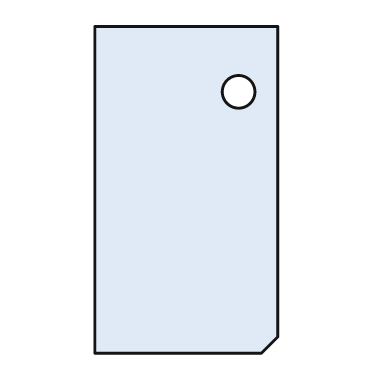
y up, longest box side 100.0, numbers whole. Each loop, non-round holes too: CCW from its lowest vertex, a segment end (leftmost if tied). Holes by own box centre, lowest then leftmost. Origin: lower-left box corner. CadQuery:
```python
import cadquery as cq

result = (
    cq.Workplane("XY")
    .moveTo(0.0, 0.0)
    .lineTo(51.0, 0.0)
    .lineTo(56.0, 5.0)
    .lineTo(56.0, 100.0)
    .lineTo(0.0, 100.0)
    .close()
    .moveTo(44.0, 80.0)
    .circle(5.0)
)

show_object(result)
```